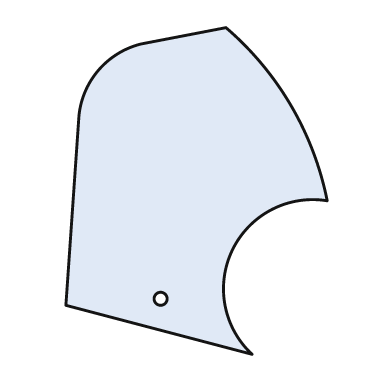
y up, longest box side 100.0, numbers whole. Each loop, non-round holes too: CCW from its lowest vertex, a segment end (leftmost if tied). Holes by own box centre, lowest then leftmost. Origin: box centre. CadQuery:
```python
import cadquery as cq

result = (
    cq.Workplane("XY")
    .moveTo(17.0, -50.0)
    .threePointArc((11.0, -18.0), (40.0, -3.0))
    .threePointArc((29.0, 26.0), (9.0, 50.0))
    .lineTo(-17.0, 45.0)
    .threePointArc((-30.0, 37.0), (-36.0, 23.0))
    .lineTo(-40.0, -35.0)
    .close()
    .moveTo(-11.0, -33.0)
    .circle(2.0)
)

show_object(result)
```